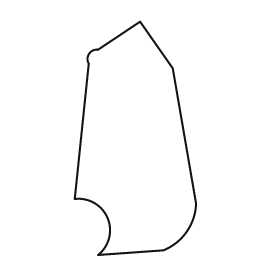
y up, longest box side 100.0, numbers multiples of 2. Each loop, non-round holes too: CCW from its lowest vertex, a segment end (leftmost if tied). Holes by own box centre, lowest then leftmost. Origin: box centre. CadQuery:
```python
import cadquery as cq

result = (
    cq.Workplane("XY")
    .moveTo(-16.0, -50.0)
    .lineTo(12.0, -48.0)
    .threePointArc((22.0, -40.0), (26.0, -28.0))
    .lineTo(16.0, 30.0)
    .lineTo(2.0, 50.0)
    .lineTo(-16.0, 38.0)
    .threePointArc((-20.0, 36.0), (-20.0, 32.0))
    .lineTo(-26.0, -26.0)
    .threePointArc((-12.0, -34.0), (-16.0, -50.0))
    .close()
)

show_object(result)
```